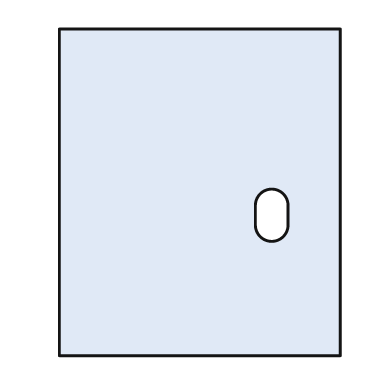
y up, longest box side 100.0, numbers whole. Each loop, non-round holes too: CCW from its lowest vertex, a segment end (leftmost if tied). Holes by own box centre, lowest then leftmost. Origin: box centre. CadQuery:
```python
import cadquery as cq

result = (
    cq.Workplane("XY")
    .moveTo(-43.0, -50.0)
    .lineTo(43.0, -50.0)
    .lineTo(43.0, 50.0)
    .lineTo(-43.0, 50.0)
    .close()
    .moveTo(17.0, -10.0)
    .threePointArc((22.0, -15.0), (27.0, -10.0))
    .lineTo(27.0, -4.0)
    .threePointArc((22.0, 1.0), (17.0, -4.0))
    .close()
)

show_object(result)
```